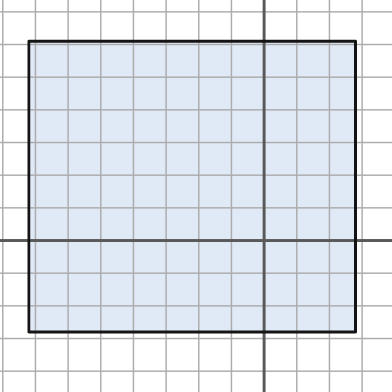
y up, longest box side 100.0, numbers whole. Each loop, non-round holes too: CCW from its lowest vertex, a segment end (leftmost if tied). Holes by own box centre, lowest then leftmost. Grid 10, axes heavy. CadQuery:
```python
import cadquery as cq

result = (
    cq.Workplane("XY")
    .moveTo(-72.0, -28.0)
    .lineTo(28.0, -28.0)
    .lineTo(28.0, 61.0)
    .lineTo(-72.0, 61.0)
    .close()
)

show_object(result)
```